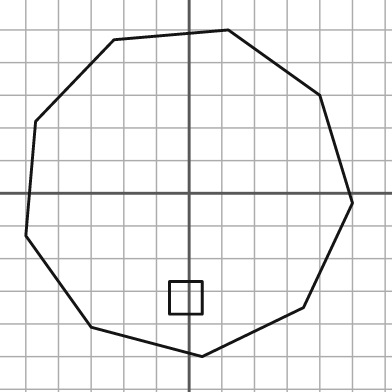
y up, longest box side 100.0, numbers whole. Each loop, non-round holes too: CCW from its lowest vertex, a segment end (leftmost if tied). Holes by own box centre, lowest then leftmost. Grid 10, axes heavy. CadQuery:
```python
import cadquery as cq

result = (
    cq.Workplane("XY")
    .moveTo(4.0, -50.0)
    .lineTo(35.0, -35.0)
    .lineTo(50.0, -3.0)
    .lineTo(40.0, 30.0)
    .lineTo(12.0, 50.0)
    .lineTo(-23.0, 47.0)
    .lineTo(-47.0, 22.0)
    .lineTo(-50.0, -13.0)
    .lineTo(-30.0, -41.0)
    .close()
    .moveTo(-6.0, -37.0)
    .lineTo(4.0, -37.0)
    .lineTo(4.0, -27.0)
    .lineTo(-6.0, -27.0)
    .close()
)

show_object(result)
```